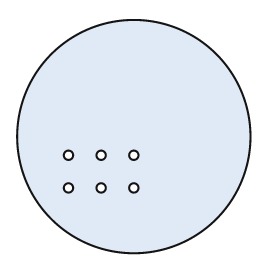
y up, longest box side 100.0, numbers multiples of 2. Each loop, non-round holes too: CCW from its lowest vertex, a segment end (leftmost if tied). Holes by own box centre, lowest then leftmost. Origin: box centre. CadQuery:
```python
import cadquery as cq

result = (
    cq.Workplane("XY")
    .moveTo(0.0, 0.0)
    .circle(50.0)
    .moveTo(-28.0, -22.0)
    .circle(2.0)
    .moveTo(-14.0, -22.0)
    .circle(2.0)
    .moveTo(0.0, -22.0)
    .circle(2.0)
    .moveTo(-28.0, -8.0)
    .circle(2.0)
    .moveTo(-14.0, -8.0)
    .circle(2.0)
    .moveTo(0.0, -8.0)
    .circle(2.0)
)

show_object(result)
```